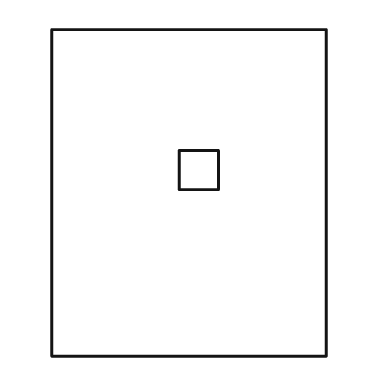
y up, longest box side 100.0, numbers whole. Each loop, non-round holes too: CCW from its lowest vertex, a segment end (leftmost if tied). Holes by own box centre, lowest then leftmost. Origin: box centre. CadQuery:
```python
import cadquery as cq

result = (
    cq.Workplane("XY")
    .moveTo(-42.0, -50.0)
    .lineTo(42.0, -50.0)
    .lineTo(42.0, 50.0)
    .lineTo(-42.0, 50.0)
    .close()
    .moveTo(-3.0, 1.0)
    .lineTo(9.0, 1.0)
    .lineTo(9.0, 13.0)
    .lineTo(-3.0, 13.0)
    .close()
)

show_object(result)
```